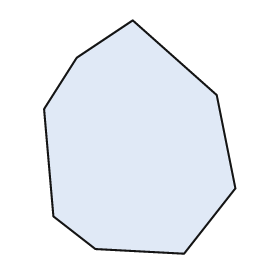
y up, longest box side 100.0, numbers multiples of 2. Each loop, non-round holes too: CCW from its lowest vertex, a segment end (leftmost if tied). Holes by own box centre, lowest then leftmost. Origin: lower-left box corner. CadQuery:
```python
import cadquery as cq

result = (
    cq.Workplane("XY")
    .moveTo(60.0, 0.0)
    .lineTo(82.0, 28.0)
    .lineTo(74.0, 68.0)
    .lineTo(38.0, 100.0)
    .lineTo(14.0, 84.0)
    .lineTo(0.0, 62.0)
    .lineTo(4.0, 16.0)
    .lineTo(22.0, 2.0)
    .close()
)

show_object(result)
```